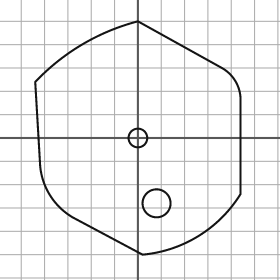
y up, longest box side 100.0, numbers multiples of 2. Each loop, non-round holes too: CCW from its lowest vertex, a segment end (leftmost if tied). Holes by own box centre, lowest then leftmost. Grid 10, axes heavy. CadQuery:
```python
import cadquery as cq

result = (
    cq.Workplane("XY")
    .moveTo(2.0, -50.0)
    .threePointArc((26.0, -42.0), (44.0, -24.0))
    .lineTo(44.0, 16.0)
    .threePointArc((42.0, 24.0), (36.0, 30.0))
    .lineTo(0.0, 50.0)
    .threePointArc((-24.0, 40.0), (-44.0, 24.0))
    .lineTo(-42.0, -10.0)
    .threePointArc((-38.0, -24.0), (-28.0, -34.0))
    .close()
    .moveTo(8.0, -28.0)
    .circle(6.0)
    .moveTo(0.0, 0.0)
    .circle(4.0)
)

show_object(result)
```